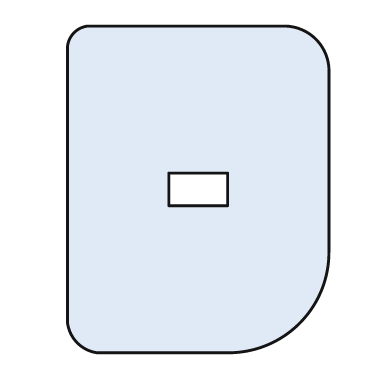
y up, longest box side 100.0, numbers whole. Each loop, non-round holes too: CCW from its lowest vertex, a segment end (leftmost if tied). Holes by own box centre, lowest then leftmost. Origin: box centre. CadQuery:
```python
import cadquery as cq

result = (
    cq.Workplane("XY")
    .moveTo(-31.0, -50.0)
    .lineTo(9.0, -50.0)
    .threePointArc((31.0, -41.0), (40.0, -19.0))
    .lineTo(40.0, 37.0)
    .threePointArc((36.0, 46.0), (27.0, 50.0))
    .lineTo(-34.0, 50.0)
    .threePointArc((-38.0, 48.0), (-40.0, 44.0))
    .lineTo(-40.0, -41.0)
    .threePointArc((-37.0, -47.0), (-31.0, -50.0))
    .close()
    .moveTo(-9.0, -5.0)
    .lineTo(9.0, -5.0)
    .lineTo(9.0, 5.0)
    .lineTo(-9.0, 5.0)
    .close()
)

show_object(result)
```